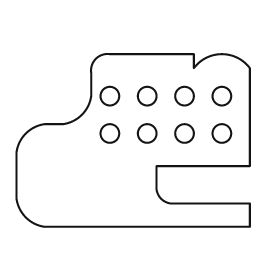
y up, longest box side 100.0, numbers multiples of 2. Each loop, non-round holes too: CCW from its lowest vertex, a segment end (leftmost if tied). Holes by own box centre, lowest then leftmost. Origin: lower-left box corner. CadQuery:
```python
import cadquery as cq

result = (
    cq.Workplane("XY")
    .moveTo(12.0, 0.0)
    .lineTo(100.0, 0.0)
    .lineTo(100.0, 10.0)
    .lineTo(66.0, 10.0)
    .threePointArc((62.0, 12.0), (60.0, 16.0))
    .lineTo(60.0, 26.0)
    .lineTo(100.0, 26.0)
    .lineTo(100.0, 68.0)
    .threePointArc((88.0, 74.0), (76.0, 68.0))
    .lineTo(76.0, 74.0)
    .lineTo(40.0, 74.0)
    .threePointArc((34.0, 72.0), (32.0, 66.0))
    .lineTo(32.0, 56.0)
    .threePointArc((28.0, 48.0), (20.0, 44.0))
    .lineTo(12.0, 44.0)
    .threePointArc((4.0, 40.0), (0.0, 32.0))
    .lineTo(0.0, 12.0)
    .threePointArc((4.0, 4.0), (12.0, 0.0))
    .close()
    .moveTo(40.0, 40.0)
    .circle(4.0)
    .moveTo(56.0, 40.0)
    .circle(4.0)
    .moveTo(72.0, 40.0)
    .circle(4.0)
    .moveTo(88.0, 40.0)
    .circle(4.0)
    .moveTo(40.0, 56.0)
    .circle(4.0)
    .moveTo(56.0, 56.0)
    .circle(4.0)
    .moveTo(72.0, 56.0)
    .circle(4.0)
    .moveTo(88.0, 56.0)
    .circle(4.0)
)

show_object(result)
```